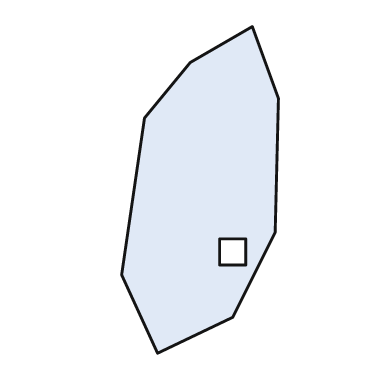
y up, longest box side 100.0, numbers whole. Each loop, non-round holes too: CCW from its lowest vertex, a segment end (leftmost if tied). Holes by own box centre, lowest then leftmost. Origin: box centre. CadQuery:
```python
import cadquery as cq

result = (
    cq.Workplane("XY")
    .moveTo(-13.0, -50.0)
    .lineTo(10.0, -39.0)
    .lineTo(23.0, -13.0)
    .lineTo(24.0, 28.0)
    .lineTo(16.0, 50.0)
    .lineTo(-3.0, 39.0)
    .lineTo(-17.0, 22.0)
    .lineTo(-24.0, -26.0)
    .close()
    .moveTo(6.0, -23.0)
    .lineTo(14.0, -23.0)
    .lineTo(14.0, -15.0)
    .lineTo(6.0, -15.0)
    .close()
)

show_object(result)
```